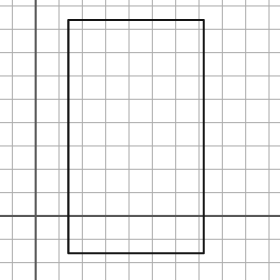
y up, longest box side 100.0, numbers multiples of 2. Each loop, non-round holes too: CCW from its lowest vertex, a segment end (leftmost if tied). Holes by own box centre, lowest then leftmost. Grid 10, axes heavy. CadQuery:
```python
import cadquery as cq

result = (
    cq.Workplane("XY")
    .moveTo(14.0, -16.0)
    .lineTo(72.0, -16.0)
    .lineTo(72.0, 84.0)
    .lineTo(14.0, 84.0)
    .close()
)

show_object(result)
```